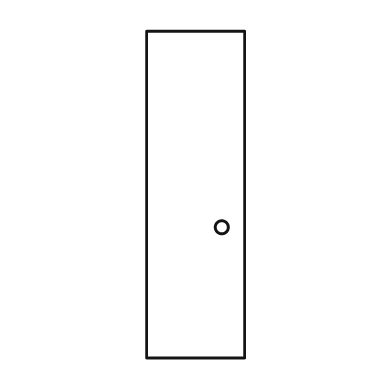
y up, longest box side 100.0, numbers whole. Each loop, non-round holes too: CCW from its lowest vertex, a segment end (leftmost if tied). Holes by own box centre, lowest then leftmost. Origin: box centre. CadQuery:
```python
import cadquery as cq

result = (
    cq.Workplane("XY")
    .moveTo(-15.0, -50.0)
    .lineTo(15.0, -50.0)
    .lineTo(15.0, 50.0)
    .lineTo(-15.0, 50.0)
    .close()
    .moveTo(8.0, -10.0)
    .circle(2.0)
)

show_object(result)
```